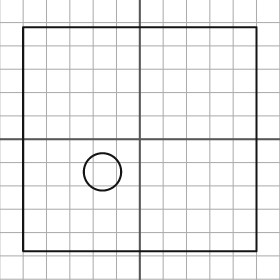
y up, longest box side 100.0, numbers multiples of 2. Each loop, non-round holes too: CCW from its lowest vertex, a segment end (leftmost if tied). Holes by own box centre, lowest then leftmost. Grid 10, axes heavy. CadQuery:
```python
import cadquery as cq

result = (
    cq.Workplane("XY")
    .moveTo(-50.0, -48.0)
    .lineTo(50.0, -48.0)
    .lineTo(50.0, 48.0)
    .lineTo(-50.0, 48.0)
    .close()
    .moveTo(-16.0, -14.0)
    .circle(8.0)
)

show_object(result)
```